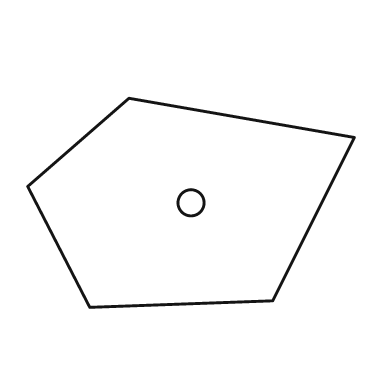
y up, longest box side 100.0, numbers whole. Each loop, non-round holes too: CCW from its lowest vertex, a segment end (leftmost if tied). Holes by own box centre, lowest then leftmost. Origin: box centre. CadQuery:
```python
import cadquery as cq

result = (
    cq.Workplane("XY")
    .moveTo(-31.0, -32.0)
    .lineTo(25.0, -30.0)
    .lineTo(50.0, 20.0)
    .lineTo(-19.0, 32.0)
    .lineTo(-50.0, 5.0)
    .close()
    .moveTo(0.0, 0.0)
    .circle(4.0)
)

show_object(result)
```